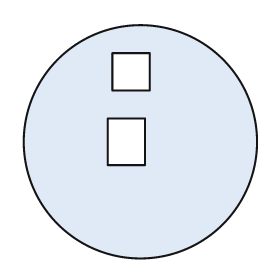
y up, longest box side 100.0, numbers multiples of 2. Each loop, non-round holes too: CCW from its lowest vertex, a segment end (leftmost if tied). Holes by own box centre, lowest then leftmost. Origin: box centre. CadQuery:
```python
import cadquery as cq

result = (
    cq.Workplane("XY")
    .moveTo(0.0, 0.0)
    .circle(50.0)
    .moveTo(-14.0, -10.0)
    .lineTo(2.0, -10.0)
    .lineTo(2.0, 10.0)
    .lineTo(-14.0, 10.0)
    .close()
    .moveTo(-12.0, 22.0)
    .lineTo(4.0, 22.0)
    .lineTo(4.0, 38.0)
    .lineTo(-12.0, 38.0)
    .close()
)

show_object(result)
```